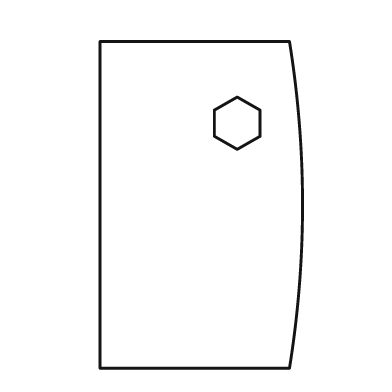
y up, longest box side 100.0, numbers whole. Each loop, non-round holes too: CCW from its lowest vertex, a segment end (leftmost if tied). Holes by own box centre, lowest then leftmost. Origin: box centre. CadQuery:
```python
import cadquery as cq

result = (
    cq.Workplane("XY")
    .moveTo(-31.0, -50.0)
    .lineTo(27.0, -50.0)
    .threePointArc((31.0, 0.0), (27.0, 50.0))
    .lineTo(-31.0, 50.0)
    .close()
    .moveTo(11.0, 17.0)
    .lineTo(18.0, 21.0)
    .lineTo(18.0, 29.0)
    .lineTo(11.0, 33.0)
    .lineTo(4.0, 29.0)
    .lineTo(4.0, 21.0)
    .close()
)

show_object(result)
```